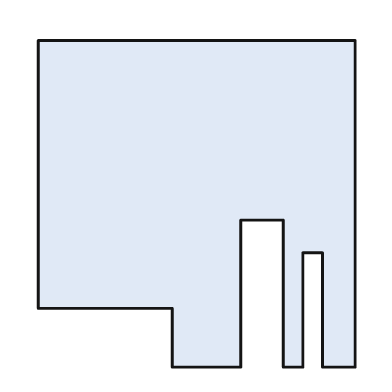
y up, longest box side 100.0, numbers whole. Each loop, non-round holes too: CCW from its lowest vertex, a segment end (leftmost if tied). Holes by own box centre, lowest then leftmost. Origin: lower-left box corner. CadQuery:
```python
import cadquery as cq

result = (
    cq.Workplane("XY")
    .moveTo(41.0, 0.0)
    .lineTo(62.0, 0.0)
    .lineTo(62.0, 45.0)
    .lineTo(75.0, 45.0)
    .lineTo(75.0, 0.0)
    .lineTo(81.0, 0.0)
    .lineTo(81.0, 35.0)
    .lineTo(87.0, 35.0)
    .lineTo(87.0, 0.0)
    .lineTo(97.0, 0.0)
    .lineTo(97.0, 100.0)
    .lineTo(0.0, 100.0)
    .lineTo(0.0, 18.0)
    .lineTo(41.0, 18.0)
    .close()
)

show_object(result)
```